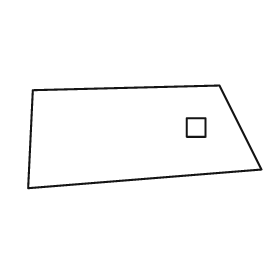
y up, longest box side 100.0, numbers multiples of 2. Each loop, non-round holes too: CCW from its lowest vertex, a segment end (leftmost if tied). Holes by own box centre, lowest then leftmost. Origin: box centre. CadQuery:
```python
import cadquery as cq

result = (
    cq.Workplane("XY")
    .moveTo(-50.0, -22.0)
    .lineTo(50.0, -14.0)
    .lineTo(32.0, 22.0)
    .lineTo(-48.0, 20.0)
    .close()
    .moveTo(18.0, 0.0)
    .lineTo(26.0, 0.0)
    .lineTo(26.0, 8.0)
    .lineTo(18.0, 8.0)
    .close()
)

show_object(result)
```